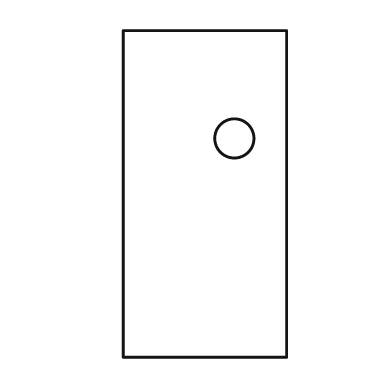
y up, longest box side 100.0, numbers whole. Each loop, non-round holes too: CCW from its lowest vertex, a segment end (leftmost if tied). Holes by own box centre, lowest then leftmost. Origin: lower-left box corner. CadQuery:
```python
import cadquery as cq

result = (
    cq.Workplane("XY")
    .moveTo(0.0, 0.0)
    .lineTo(50.0, 0.0)
    .lineTo(50.0, 100.0)
    .lineTo(0.0, 100.0)
    .close()
    .moveTo(34.0, 67.0)
    .circle(6.0)
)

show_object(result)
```